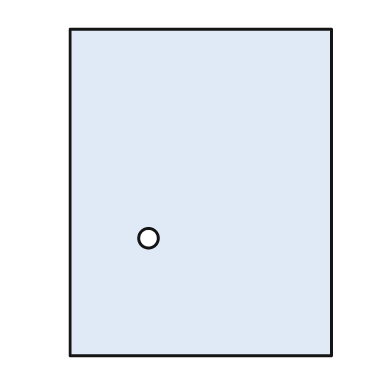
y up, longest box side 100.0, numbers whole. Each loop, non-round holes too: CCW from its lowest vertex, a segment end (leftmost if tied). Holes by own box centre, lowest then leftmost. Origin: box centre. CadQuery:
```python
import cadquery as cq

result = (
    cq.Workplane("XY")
    .moveTo(-40.0, -50.0)
    .lineTo(40.0, -50.0)
    .lineTo(40.0, 50.0)
    .lineTo(-40.0, 50.0)
    .close()
    .moveTo(-16.0, -14.0)
    .circle(3.0)
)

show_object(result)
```